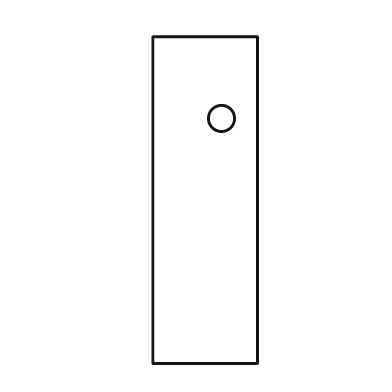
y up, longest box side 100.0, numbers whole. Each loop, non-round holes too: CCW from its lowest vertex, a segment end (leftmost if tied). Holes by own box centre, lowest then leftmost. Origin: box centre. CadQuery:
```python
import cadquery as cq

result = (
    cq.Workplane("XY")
    .moveTo(-16.0, -50.0)
    .lineTo(16.0, -50.0)
    .lineTo(16.0, 50.0)
    .lineTo(-16.0, 50.0)
    .close()
    .moveTo(5.0, 25.0)
    .circle(4.0)
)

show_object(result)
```